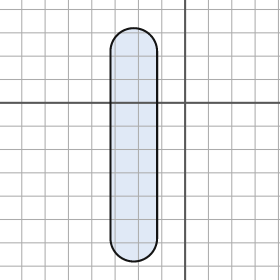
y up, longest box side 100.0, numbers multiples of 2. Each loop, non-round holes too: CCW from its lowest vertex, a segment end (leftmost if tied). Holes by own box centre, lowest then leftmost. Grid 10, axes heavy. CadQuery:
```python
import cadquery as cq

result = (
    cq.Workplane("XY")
    .moveTo(-32.0, -58.0)
    .threePointArc((-22.0, -68.0), (-12.0, -58.0))
    .lineTo(-12.0, 22.0)
    .threePointArc((-22.0, 32.0), (-32.0, 22.0))
    .close()
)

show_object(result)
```